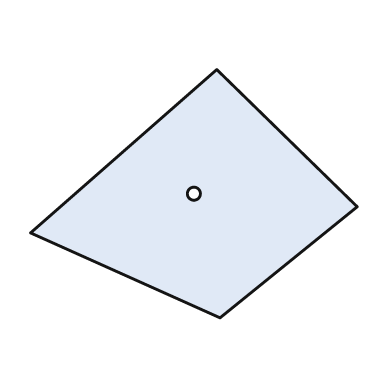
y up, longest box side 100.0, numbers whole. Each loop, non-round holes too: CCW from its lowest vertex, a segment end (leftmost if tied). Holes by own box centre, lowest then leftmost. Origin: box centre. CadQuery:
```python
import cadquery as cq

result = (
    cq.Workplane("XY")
    .moveTo(8.0, -38.0)
    .lineTo(50.0, -4.0)
    .lineTo(7.0, 38.0)
    .lineTo(-50.0, -12.0)
    .close()
    .moveTo(0.0, 0.0)
    .circle(2.0)
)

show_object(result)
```